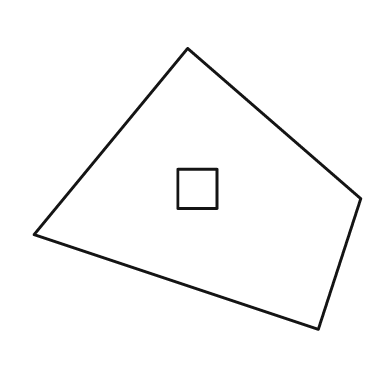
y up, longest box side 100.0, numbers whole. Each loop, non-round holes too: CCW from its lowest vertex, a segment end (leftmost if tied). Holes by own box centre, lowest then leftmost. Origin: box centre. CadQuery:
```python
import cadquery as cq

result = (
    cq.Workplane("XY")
    .moveTo(37.0, -43.0)
    .lineTo(50.0, -3.0)
    .lineTo(-3.0, 43.0)
    .lineTo(-50.0, -14.0)
    .close()
    .moveTo(-6.0, -6.0)
    .lineTo(6.0, -6.0)
    .lineTo(6.0, 6.0)
    .lineTo(-6.0, 6.0)
    .close()
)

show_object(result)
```